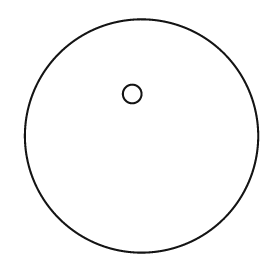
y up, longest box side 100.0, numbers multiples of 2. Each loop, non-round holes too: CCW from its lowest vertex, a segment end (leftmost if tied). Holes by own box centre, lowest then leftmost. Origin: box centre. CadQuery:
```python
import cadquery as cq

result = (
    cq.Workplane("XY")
    .moveTo(0.0, 0.0)
    .circle(50.0)
    .moveTo(-4.0, 18.0)
    .circle(4.0)
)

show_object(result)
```